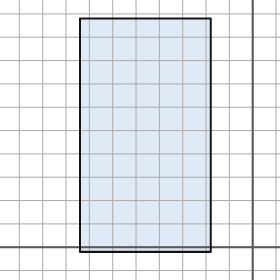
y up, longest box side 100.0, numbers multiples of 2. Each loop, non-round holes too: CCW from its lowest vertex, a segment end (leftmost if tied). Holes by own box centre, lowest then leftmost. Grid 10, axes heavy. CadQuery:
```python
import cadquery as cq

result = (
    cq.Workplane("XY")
    .moveTo(-74.0, -2.0)
    .lineTo(-18.0, -2.0)
    .lineTo(-18.0, 98.0)
    .lineTo(-74.0, 98.0)
    .close()
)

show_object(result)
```